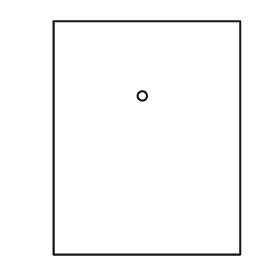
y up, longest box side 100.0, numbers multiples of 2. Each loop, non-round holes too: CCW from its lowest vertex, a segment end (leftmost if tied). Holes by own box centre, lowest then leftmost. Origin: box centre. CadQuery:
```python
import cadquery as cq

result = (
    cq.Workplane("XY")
    .moveTo(-40.0, -50.0)
    .lineTo(40.0, -50.0)
    .lineTo(40.0, 50.0)
    .lineTo(-40.0, 50.0)
    .close()
    .moveTo(-2.0, 18.0)
    .circle(2.0)
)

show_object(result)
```